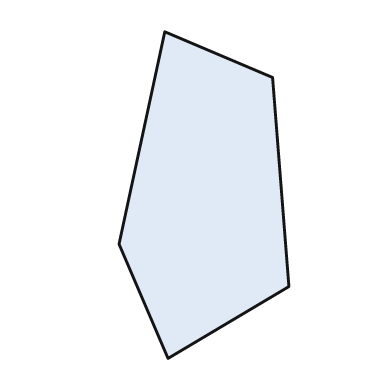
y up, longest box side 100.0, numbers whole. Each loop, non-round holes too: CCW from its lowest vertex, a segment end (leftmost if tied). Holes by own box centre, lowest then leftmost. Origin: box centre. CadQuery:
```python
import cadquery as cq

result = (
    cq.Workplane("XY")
    .moveTo(-11.0, -50.0)
    .lineTo(26.0, -28.0)
    .lineTo(21.0, 36.0)
    .lineTo(-12.0, 50.0)
    .lineTo(-26.0, -15.0)
    .close()
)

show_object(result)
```